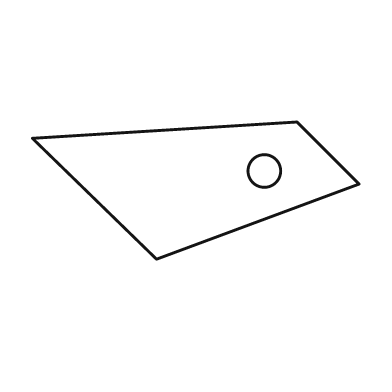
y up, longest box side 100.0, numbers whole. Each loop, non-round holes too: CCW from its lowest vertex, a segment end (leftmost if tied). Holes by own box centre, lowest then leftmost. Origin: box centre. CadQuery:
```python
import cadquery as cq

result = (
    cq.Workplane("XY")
    .moveTo(-12.0, -21.0)
    .lineTo(50.0, 2.0)
    .lineTo(31.0, 21.0)
    .lineTo(-50.0, 16.0)
    .close()
    .moveTo(21.0, 6.0)
    .circle(5.0)
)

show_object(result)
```